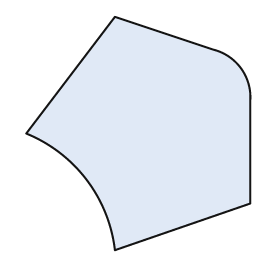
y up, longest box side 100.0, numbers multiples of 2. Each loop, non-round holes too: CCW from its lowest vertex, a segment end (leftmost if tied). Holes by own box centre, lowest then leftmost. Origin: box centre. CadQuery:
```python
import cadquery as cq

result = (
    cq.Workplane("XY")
    .moveTo(-10.0, -50.0)
    .lineTo(48.0, -30.0)
    .lineTo(48.0, 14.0)
    .threePointArc((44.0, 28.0), (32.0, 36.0))
    .lineTo(-10.0, 50.0)
    .lineTo(-48.0, 0.0)
    .threePointArc((-22.0, -20.0), (-10.0, -50.0))
    .close()
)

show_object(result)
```